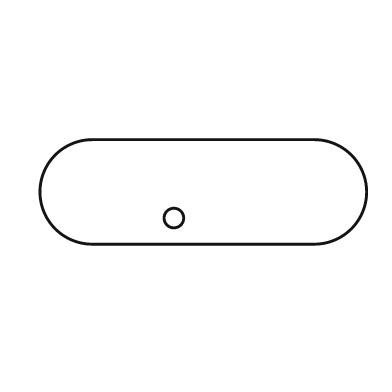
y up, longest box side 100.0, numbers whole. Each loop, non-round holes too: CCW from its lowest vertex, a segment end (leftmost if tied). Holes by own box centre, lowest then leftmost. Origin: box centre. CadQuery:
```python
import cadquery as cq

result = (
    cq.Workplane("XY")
    .moveTo(-34.0, -16.0)
    .lineTo(34.0, -16.0)
    .threePointArc((50.0, 0.0), (34.0, 16.0))
    .lineTo(-34.0, 16.0)
    .threePointArc((-50.0, 0.0), (-34.0, -16.0))
    .close()
    .moveTo(-9.0, -8.0)
    .circle(3.0)
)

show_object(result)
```